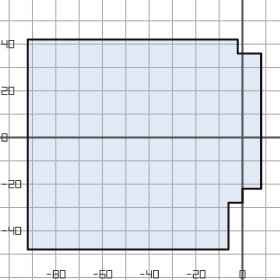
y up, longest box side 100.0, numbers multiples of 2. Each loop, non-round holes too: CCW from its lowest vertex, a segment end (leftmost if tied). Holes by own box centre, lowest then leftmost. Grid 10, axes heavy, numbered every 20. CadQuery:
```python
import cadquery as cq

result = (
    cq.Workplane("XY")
    .moveTo(-92.0, -48.0)
    .lineTo(-6.0, -48.0)
    .lineTo(-6.0, -28.0)
    .lineTo(0.0, -28.0)
    .lineTo(0.0, -22.0)
    .lineTo(8.0, -22.0)
    .lineTo(8.0, 36.0)
    .lineTo(-2.0, 36.0)
    .lineTo(-2.0, 42.0)
    .lineTo(-92.0, 42.0)
    .close()
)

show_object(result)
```